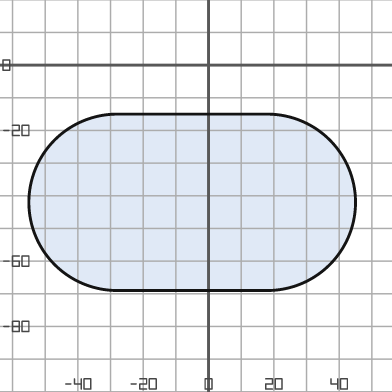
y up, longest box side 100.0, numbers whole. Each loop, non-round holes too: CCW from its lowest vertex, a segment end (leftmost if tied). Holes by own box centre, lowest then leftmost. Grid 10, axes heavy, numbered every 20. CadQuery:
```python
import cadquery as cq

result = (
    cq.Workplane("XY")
    .moveTo(-28.0, -69.0)
    .lineTo(18.0, -69.0)
    .threePointArc((45.0, -42.0), (18.0, -15.0))
    .lineTo(-28.0, -15.0)
    .threePointArc((-55.0, -42.0), (-28.0, -69.0))
    .close()
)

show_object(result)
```